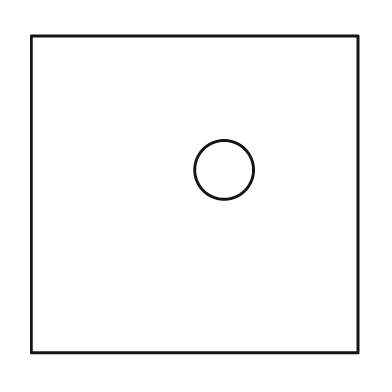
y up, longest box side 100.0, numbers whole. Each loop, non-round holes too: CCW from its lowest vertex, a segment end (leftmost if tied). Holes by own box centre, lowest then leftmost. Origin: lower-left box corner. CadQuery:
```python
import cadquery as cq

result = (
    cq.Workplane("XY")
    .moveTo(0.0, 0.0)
    .lineTo(100.0, 0.0)
    .lineTo(100.0, 97.0)
    .lineTo(0.0, 97.0)
    .close()
    .moveTo(59.0, 56.0)
    .circle(9.0)
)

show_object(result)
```